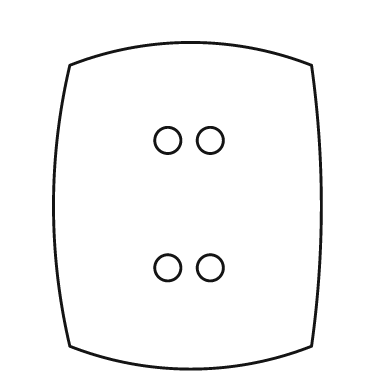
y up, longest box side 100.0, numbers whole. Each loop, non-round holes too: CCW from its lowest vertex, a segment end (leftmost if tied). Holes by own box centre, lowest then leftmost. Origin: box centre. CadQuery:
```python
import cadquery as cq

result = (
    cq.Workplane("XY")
    .moveTo(-36.0, -43.0)
    .threePointArc((1.0, -50.0), (38.0, -43.0))
    .threePointArc((41.0, 0.0), (38.0, 43.0))
    .threePointArc((1.0, 50.0), (-36.0, 43.0))
    .threePointArc((-41.0, 0.0), (-36.0, -43.0))
    .close()
    .moveTo(-6.0, -19.0)
    .circle(4.0)
    .moveTo(7.0, -19.0)
    .circle(4.0)
    .moveTo(-6.0, 20.0)
    .circle(4.0)
    .moveTo(7.0, 20.0)
    .circle(4.0)
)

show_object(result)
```